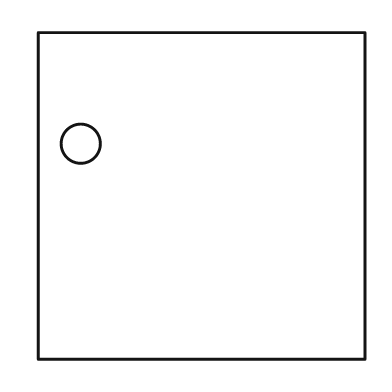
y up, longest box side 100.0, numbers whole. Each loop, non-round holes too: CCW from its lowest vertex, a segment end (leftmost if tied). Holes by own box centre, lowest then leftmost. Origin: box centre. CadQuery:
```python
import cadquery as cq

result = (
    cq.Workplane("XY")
    .moveTo(-50.0, -50.0)
    .lineTo(50.0, -50.0)
    .lineTo(50.0, 50.0)
    .lineTo(-50.0, 50.0)
    .close()
    .moveTo(-37.0, 16.0)
    .circle(6.0)
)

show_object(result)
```